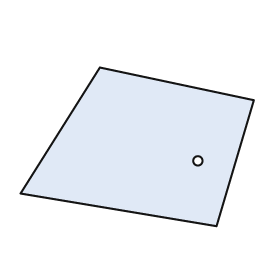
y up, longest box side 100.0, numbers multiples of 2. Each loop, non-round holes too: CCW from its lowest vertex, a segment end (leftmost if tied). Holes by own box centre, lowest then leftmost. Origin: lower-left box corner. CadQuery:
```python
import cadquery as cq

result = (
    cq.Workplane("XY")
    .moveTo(84.0, 0.0)
    .lineTo(100.0, 54.0)
    .lineTo(34.0, 68.0)
    .lineTo(0.0, 14.0)
    .close()
    .moveTo(76.0, 28.0)
    .circle(2.0)
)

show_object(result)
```